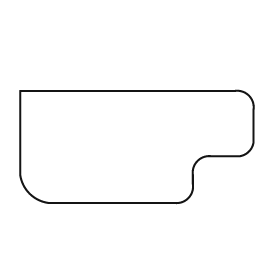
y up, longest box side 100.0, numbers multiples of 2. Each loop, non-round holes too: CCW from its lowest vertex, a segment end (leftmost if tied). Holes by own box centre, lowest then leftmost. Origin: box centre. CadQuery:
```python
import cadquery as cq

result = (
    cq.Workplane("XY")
    .moveTo(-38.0, -24.0)
    .lineTo(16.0, -24.0)
    .threePointArc((22.0, -22.0), (24.0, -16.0))
    .lineTo(24.0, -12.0)
    .threePointArc((26.0, -6.0), (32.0, -4.0))
    .lineTo(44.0, -4.0)
    .threePointArc((48.0, -2.0), (50.0, 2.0))
    .lineTo(50.0, 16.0)
    .threePointArc((48.0, 22.0), (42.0, 24.0))
    .lineTo(-50.0, 24.0)
    .lineTo(-50.0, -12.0)
    .threePointArc((-46.0, -20.0), (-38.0, -24.0))
    .close()
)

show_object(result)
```